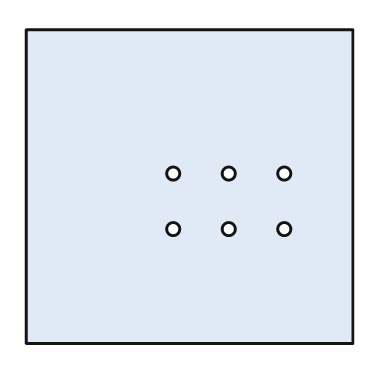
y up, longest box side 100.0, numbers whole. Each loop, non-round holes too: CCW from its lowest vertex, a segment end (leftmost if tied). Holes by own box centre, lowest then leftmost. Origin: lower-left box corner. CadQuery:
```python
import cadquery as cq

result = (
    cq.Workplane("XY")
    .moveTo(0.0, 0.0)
    .lineTo(100.0, 0.0)
    .lineTo(100.0, 96.0)
    .lineTo(0.0, 96.0)
    .close()
    .moveTo(45.0, 35.0)
    .circle(2.0)
    .moveTo(62.0, 35.0)
    .circle(2.0)
    .moveTo(79.0, 35.0)
    .circle(2.0)
    .moveTo(45.0, 52.0)
    .circle(2.0)
    .moveTo(62.0, 52.0)
    .circle(2.0)
    .moveTo(79.0, 52.0)
    .circle(2.0)
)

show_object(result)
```